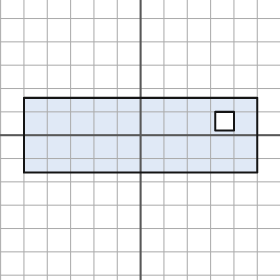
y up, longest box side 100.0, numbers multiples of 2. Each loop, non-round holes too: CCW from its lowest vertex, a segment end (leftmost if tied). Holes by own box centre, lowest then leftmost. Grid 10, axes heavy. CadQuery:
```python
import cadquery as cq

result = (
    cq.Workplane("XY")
    .moveTo(-50.0, -16.0)
    .lineTo(50.0, -16.0)
    .lineTo(50.0, 16.0)
    .lineTo(-50.0, 16.0)
    .close()
    .moveTo(32.0, 2.0)
    .lineTo(40.0, 2.0)
    .lineTo(40.0, 10.0)
    .lineTo(32.0, 10.0)
    .close()
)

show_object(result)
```